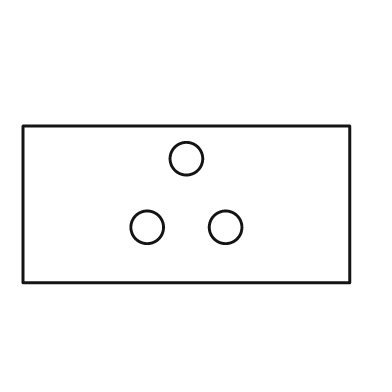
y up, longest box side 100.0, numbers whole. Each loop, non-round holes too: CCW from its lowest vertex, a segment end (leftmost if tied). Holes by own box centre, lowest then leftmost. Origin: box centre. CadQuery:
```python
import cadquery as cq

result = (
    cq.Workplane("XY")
    .moveTo(-50.0, -24.0)
    .lineTo(50.0, -24.0)
    .lineTo(50.0, 24.0)
    .lineTo(-50.0, 24.0)
    .close()
    .moveTo(-12.0, -7.0)
    .circle(5.0)
    .moveTo(12.0, -7.0)
    .circle(5.0)
    .moveTo(0.0, 14.0)
    .circle(5.0)
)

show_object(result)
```